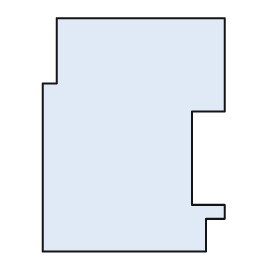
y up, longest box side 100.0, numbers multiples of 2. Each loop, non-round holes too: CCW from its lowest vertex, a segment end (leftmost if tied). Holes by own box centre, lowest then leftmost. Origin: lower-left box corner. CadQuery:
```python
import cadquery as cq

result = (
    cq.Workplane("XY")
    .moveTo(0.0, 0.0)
    .lineTo(70.0, 0.0)
    .lineTo(70.0, 14.0)
    .lineTo(78.0, 14.0)
    .lineTo(78.0, 20.0)
    .lineTo(64.0, 20.0)
    .lineTo(64.0, 60.0)
    .lineTo(78.0, 60.0)
    .lineTo(78.0, 100.0)
    .lineTo(6.0, 100.0)
    .lineTo(6.0, 72.0)
    .lineTo(0.0, 72.0)
    .close()
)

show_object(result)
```